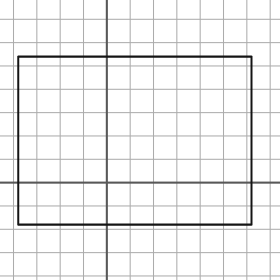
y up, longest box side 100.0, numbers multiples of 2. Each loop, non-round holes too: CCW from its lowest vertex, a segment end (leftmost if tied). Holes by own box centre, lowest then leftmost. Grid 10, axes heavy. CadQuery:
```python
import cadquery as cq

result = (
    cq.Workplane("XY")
    .moveTo(-38.0, -18.0)
    .lineTo(62.0, -18.0)
    .lineTo(62.0, 54.0)
    .lineTo(-38.0, 54.0)
    .close()
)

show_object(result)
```